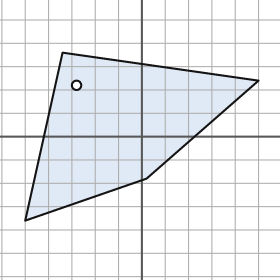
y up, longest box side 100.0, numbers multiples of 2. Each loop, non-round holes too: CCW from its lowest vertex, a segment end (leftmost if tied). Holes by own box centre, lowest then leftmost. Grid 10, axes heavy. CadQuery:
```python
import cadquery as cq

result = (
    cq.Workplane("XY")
    .moveTo(-50.0, -36.0)
    .lineTo(2.0, -18.0)
    .lineTo(50.0, 24.0)
    .lineTo(-34.0, 36.0)
    .close()
    .moveTo(-28.0, 22.0)
    .circle(2.0)
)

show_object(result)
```